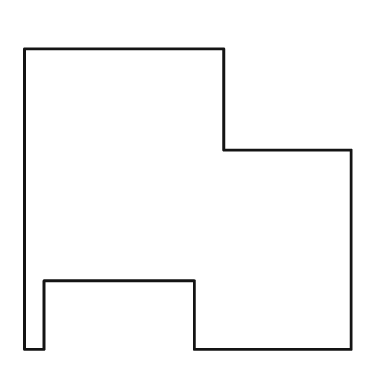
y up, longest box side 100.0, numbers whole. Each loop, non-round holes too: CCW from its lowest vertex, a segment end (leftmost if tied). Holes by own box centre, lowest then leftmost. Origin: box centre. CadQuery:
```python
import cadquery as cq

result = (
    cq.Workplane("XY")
    .moveTo(-50.0, -46.0)
    .lineTo(-44.0, -46.0)
    .lineTo(-44.0, -25.0)
    .lineTo(2.0, -25.0)
    .lineTo(2.0, -46.0)
    .lineTo(50.0, -46.0)
    .lineTo(50.0, 15.0)
    .lineTo(11.0, 15.0)
    .lineTo(11.0, 46.0)
    .lineTo(-50.0, 46.0)
    .close()
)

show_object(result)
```